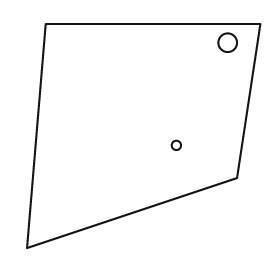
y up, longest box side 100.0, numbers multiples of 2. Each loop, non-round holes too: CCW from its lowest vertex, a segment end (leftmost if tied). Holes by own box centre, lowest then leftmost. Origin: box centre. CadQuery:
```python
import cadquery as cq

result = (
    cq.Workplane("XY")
    .moveTo(-50.0, -48.0)
    .lineTo(40.0, -18.0)
    .lineTo(50.0, 48.0)
    .lineTo(-42.0, 48.0)
    .close()
    .moveTo(14.0, -4.0)
    .circle(2.0)
    .moveTo(36.0, 40.0)
    .circle(4.0)
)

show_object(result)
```